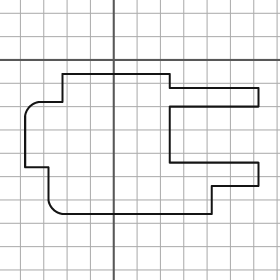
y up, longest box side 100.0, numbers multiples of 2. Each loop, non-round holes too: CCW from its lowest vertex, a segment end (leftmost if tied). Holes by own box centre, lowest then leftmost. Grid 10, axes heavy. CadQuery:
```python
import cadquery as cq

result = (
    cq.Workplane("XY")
    .moveTo(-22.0, -66.0)
    .lineTo(42.0, -66.0)
    .lineTo(42.0, -54.0)
    .lineTo(62.0, -54.0)
    .lineTo(62.0, -44.0)
    .lineTo(24.0, -44.0)
    .lineTo(24.0, -20.0)
    .lineTo(62.0, -20.0)
    .lineTo(62.0, -12.0)
    .lineTo(24.0, -12.0)
    .lineTo(24.0, -6.0)
    .lineTo(-22.0, -6.0)
    .lineTo(-22.0, -18.0)
    .lineTo(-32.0, -18.0)
    .threePointArc((-36.0, -20.0), (-38.0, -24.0))
    .lineTo(-38.0, -46.0)
    .lineTo(-28.0, -46.0)
    .lineTo(-28.0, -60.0)
    .threePointArc((-26.0, -64.0), (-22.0, -66.0))
    .close()
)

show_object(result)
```